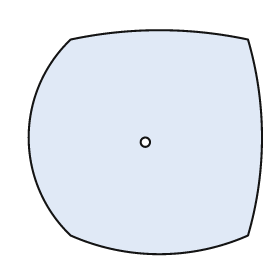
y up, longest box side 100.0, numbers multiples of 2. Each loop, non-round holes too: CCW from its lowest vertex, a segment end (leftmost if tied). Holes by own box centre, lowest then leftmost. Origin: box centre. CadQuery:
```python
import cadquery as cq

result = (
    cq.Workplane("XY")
    .moveTo(-32.0, -40.0)
    .threePointArc((6.0, -48.0), (44.0, -40.0))
    .threePointArc((50.0, 2.0), (44.0, 44.0))
    .threePointArc((6.0, 48.0), (-32.0, 44.0))
    .threePointArc((-50.0, 2.0), (-32.0, -40.0))
    .close()
    .moveTo(0.0, 0.0)
    .circle(2.0)
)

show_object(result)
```